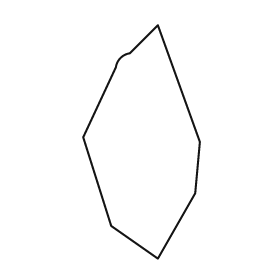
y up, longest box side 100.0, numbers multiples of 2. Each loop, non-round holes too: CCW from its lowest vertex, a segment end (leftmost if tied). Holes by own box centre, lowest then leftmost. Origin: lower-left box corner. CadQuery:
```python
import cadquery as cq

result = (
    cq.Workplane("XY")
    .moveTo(32.0, 0.0)
    .lineTo(48.0, 28.0)
    .lineTo(50.0, 50.0)
    .lineTo(32.0, 100.0)
    .lineTo(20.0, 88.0)
    .threePointArc((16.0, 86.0), (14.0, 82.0))
    .lineTo(0.0, 52.0)
    .lineTo(12.0, 14.0)
    .close()
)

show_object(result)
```